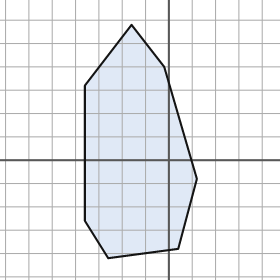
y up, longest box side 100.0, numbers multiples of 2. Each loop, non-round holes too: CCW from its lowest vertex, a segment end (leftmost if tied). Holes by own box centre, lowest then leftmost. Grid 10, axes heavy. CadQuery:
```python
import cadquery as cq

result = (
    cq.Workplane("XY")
    .moveTo(-26.0, -42.0)
    .lineTo(4.0, -38.0)
    .lineTo(12.0, -8.0)
    .lineTo(-2.0, 40.0)
    .lineTo(-16.0, 58.0)
    .lineTo(-36.0, 32.0)
    .lineTo(-36.0, -26.0)
    .close()
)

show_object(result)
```